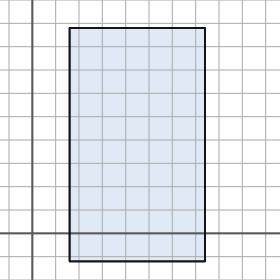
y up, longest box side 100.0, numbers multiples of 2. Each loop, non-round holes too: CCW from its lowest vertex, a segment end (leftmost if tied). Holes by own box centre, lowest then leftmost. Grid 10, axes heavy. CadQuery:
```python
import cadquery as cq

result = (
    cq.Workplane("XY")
    .moveTo(16.0, -12.0)
    .lineTo(74.0, -12.0)
    .lineTo(74.0, 88.0)
    .lineTo(16.0, 88.0)
    .close()
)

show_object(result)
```